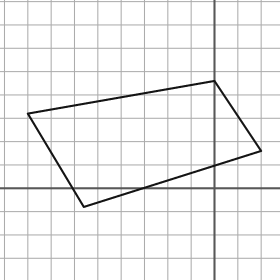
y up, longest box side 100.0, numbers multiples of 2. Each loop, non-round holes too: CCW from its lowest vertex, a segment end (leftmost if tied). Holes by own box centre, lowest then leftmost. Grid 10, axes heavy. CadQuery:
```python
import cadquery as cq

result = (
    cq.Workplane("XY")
    .moveTo(-56.0, -8.0)
    .lineTo(20.0, 16.0)
    .lineTo(0.0, 46.0)
    .lineTo(-80.0, 32.0)
    .close()
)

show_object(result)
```